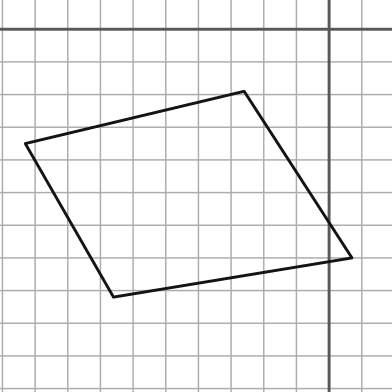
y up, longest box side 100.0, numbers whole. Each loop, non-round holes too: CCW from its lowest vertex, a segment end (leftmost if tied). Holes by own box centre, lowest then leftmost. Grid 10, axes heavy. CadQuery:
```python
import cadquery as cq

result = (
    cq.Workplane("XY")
    .moveTo(-66.0, -82.0)
    .lineTo(7.0, -70.0)
    .lineTo(-26.0, -19.0)
    .lineTo(-93.0, -35.0)
    .close()
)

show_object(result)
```